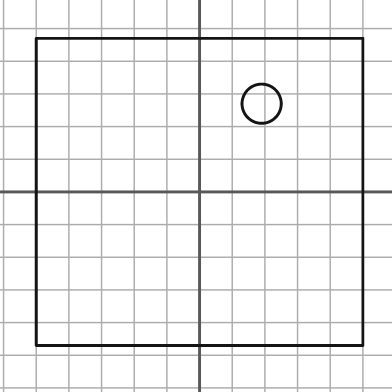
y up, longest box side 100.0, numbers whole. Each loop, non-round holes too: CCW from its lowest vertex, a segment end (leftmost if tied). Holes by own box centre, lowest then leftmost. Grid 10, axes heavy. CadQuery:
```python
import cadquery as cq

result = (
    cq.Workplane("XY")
    .moveTo(-50.0, -47.0)
    .lineTo(50.0, -47.0)
    .lineTo(50.0, 47.0)
    .lineTo(-50.0, 47.0)
    .close()
    .moveTo(19.0, 27.0)
    .circle(6.0)
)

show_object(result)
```